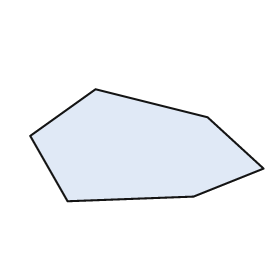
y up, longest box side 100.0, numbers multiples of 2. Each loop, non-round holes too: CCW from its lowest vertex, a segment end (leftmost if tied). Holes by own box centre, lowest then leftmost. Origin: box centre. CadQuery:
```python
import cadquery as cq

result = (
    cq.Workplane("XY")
    .moveTo(-34.0, -24.0)
    .lineTo(20.0, -22.0)
    .lineTo(50.0, -10.0)
    .lineTo(26.0, 12.0)
    .lineTo(-22.0, 24.0)
    .lineTo(-50.0, 4.0)
    .close()
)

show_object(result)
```